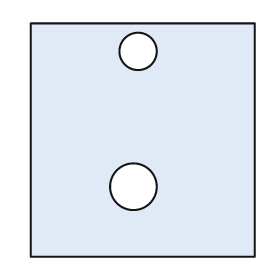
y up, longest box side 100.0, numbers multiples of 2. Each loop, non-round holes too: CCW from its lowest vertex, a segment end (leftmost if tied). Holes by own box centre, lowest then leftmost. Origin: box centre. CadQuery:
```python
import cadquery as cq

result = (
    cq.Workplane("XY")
    .moveTo(-48.0, -50.0)
    .lineTo(48.0, -50.0)
    .lineTo(48.0, 50.0)
    .lineTo(-48.0, 50.0)
    .close()
    .moveTo(-4.0, -20.0)
    .circle(10.0)
    .moveTo(-2.0, 38.0)
    .circle(8.0)
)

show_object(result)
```